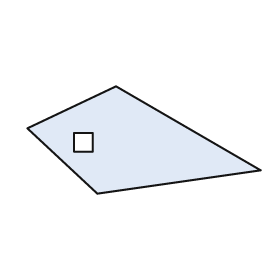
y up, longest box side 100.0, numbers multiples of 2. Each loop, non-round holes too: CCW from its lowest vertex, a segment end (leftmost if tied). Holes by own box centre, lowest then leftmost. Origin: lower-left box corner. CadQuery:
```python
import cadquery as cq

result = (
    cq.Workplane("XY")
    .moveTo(30.0, 0.0)
    .lineTo(100.0, 10.0)
    .lineTo(38.0, 46.0)
    .lineTo(0.0, 28.0)
    .close()
    .moveTo(20.0, 18.0)
    .lineTo(28.0, 18.0)
    .lineTo(28.0, 26.0)
    .lineTo(20.0, 26.0)
    .close()
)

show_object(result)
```